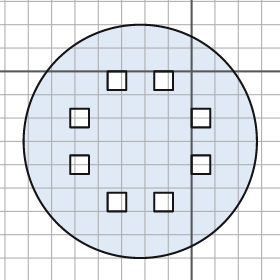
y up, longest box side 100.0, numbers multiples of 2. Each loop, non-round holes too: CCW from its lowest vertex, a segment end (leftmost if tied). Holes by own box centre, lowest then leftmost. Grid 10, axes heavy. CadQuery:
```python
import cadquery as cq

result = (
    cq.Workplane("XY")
    .moveTo(-22.0, -30.0)
    .circle(50.0)
    .moveTo(-36.0, -60.0)
    .lineTo(-28.0, -60.0)
    .lineTo(-28.0, -52.0)
    .lineTo(-36.0, -52.0)
    .close()
    .moveTo(-16.0, -60.0)
    .lineTo(-8.0, -60.0)
    .lineTo(-8.0, -52.0)
    .lineTo(-16.0, -52.0)
    .close()
    .moveTo(-52.0, -44.0)
    .lineTo(-44.0, -44.0)
    .lineTo(-44.0, -36.0)
    .lineTo(-52.0, -36.0)
    .close()
    .moveTo(0.0, -44.0)
    .lineTo(8.0, -44.0)
    .lineTo(8.0, -36.0)
    .lineTo(0.0, -36.0)
    .close()
    .moveTo(-52.0, -24.0)
    .lineTo(-44.0, -24.0)
    .lineTo(-44.0, -16.0)
    .lineTo(-52.0, -16.0)
    .close()
    .moveTo(0.0, -24.0)
    .lineTo(8.0, -24.0)
    .lineTo(8.0, -16.0)
    .lineTo(0.0, -16.0)
    .close()
    .moveTo(-36.0, -8.0)
    .lineTo(-28.0, -8.0)
    .lineTo(-28.0, 0.0)
    .lineTo(-36.0, 0.0)
    .close()
    .moveTo(-16.0, -8.0)
    .lineTo(-8.0, -8.0)
    .lineTo(-8.0, 0.0)
    .lineTo(-16.0, 0.0)
    .close()
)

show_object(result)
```